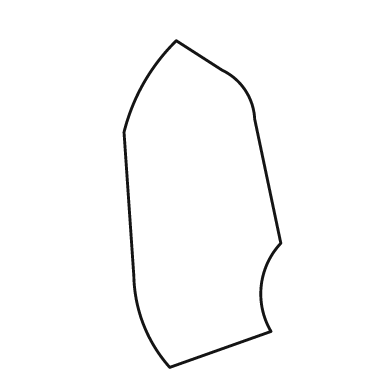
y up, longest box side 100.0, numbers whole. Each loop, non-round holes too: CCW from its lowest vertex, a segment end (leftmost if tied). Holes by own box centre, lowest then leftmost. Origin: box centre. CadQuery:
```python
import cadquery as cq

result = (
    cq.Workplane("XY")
    .moveTo(-10.0, -50.0)
    .lineTo(21.0, -39.0)
    .threePointArc((18.0, -25.0), (24.0, -12.0))
    .lineTo(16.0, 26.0)
    .threePointArc((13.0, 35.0), (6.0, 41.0))
    .lineTo(-8.0, 50.0)
    .threePointArc((-18.0, 37.0), (-24.0, 22.0))
    .lineTo(-21.0, -22.0)
    .threePointArc((-18.0, -37.0), (-10.0, -50.0))
    .close()
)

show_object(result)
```